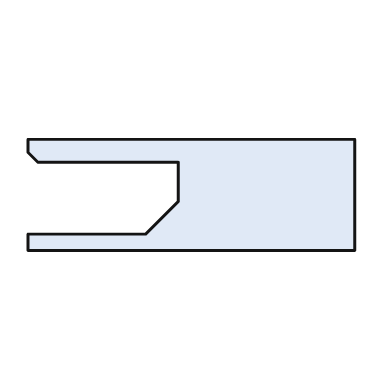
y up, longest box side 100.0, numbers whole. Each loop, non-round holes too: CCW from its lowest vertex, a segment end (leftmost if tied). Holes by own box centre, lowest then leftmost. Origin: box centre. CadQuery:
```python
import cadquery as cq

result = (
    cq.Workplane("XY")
    .moveTo(-50.0, -17.0)
    .lineTo(50.0, -17.0)
    .lineTo(50.0, 17.0)
    .lineTo(-50.0, 17.0)
    .lineTo(-50.0, 13.0)
    .lineTo(-47.0, 10.0)
    .lineTo(-4.0, 10.0)
    .lineTo(-4.0, -2.0)
    .lineTo(-14.0, -12.0)
    .lineTo(-50.0, -12.0)
    .close()
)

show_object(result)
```